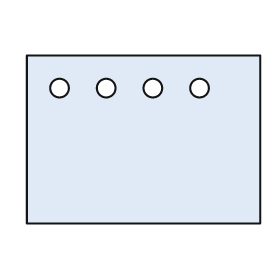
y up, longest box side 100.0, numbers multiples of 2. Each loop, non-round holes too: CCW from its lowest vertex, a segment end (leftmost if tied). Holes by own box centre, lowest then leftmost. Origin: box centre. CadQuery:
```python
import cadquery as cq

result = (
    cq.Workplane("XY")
    .moveTo(-50.0, -36.0)
    .lineTo(50.0, -36.0)
    .lineTo(50.0, 36.0)
    .lineTo(-50.0, 36.0)
    .close()
    .moveTo(-36.0, 22.0)
    .circle(4.0)
    .moveTo(-16.0, 22.0)
    .circle(4.0)
    .moveTo(4.0, 22.0)
    .circle(4.0)
    .moveTo(24.0, 22.0)
    .circle(4.0)
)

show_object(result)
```